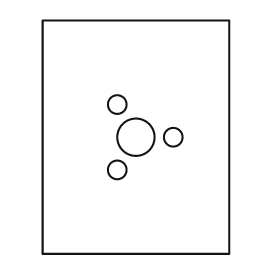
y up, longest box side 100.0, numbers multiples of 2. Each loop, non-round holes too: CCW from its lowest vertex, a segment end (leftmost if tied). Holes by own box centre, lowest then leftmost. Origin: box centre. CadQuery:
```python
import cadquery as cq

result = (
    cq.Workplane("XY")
    .moveTo(-40.0, -50.0)
    .lineTo(40.0, -50.0)
    .lineTo(40.0, 50.0)
    .lineTo(-40.0, 50.0)
    .close()
    .moveTo(-8.0, -14.0)
    .circle(4.0)
    .moveTo(0.0, 0.0)
    .circle(8.0)
    .moveTo(16.0, 0.0)
    .circle(4.0)
    .moveTo(-8.0, 14.0)
    .circle(4.0)
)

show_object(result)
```